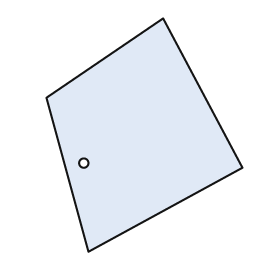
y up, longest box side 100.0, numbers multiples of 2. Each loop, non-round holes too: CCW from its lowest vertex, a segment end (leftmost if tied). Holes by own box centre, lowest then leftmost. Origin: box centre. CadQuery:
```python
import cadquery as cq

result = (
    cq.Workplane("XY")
    .moveTo(-24.0, -50.0)
    .lineTo(42.0, -14.0)
    .lineTo(8.0, 50.0)
    .lineTo(-42.0, 16.0)
    .close()
    .moveTo(-26.0, -12.0)
    .circle(2.0)
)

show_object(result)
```